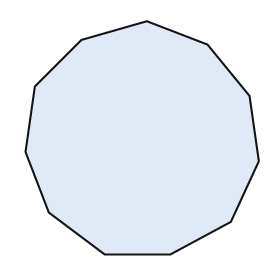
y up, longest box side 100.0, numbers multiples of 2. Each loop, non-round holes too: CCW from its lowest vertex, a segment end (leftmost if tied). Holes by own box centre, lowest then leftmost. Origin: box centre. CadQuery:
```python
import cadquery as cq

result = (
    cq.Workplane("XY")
    .moveTo(-16.0, -50.0)
    .lineTo(12.0, -50.0)
    .lineTo(38.0, -36.0)
    .lineTo(50.0, -10.0)
    .lineTo(46.0, 18.0)
    .lineTo(28.0, 40.0)
    .lineTo(2.0, 50.0)
    .lineTo(-26.0, 42.0)
    .lineTo(-46.0, 22.0)
    .lineTo(-50.0, -6.0)
    .lineTo(-40.0, -32.0)
    .close()
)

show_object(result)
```